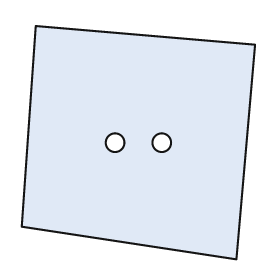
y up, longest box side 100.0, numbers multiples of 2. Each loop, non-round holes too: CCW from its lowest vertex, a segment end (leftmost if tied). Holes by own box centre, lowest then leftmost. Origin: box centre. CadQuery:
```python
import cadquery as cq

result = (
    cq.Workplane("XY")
    .moveTo(42.0, -50.0)
    .lineTo(50.0, 42.0)
    .lineTo(-44.0, 50.0)
    .lineTo(-50.0, -36.0)
    .close()
    .moveTo(-10.0, 0.0)
    .circle(4.0)
    .moveTo(10.0, 0.0)
    .circle(4.0)
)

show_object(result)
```